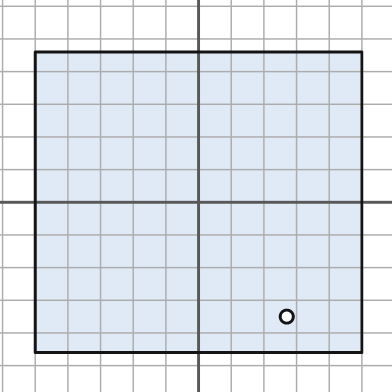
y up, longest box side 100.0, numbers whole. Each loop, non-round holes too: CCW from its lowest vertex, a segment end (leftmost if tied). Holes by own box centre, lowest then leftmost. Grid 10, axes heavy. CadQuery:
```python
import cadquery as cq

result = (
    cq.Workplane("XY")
    .moveTo(-50.0, -46.0)
    .lineTo(50.0, -46.0)
    .lineTo(50.0, 46.0)
    .lineTo(-50.0, 46.0)
    .close()
    .moveTo(27.0, -35.0)
    .circle(2.0)
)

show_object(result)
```